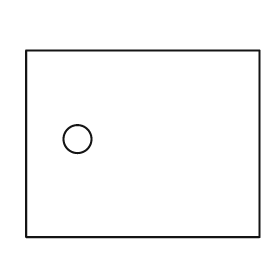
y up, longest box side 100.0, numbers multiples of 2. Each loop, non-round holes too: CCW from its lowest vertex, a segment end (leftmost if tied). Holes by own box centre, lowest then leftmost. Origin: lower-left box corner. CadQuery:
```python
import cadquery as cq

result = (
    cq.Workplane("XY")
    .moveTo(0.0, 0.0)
    .lineTo(100.0, 0.0)
    .lineTo(100.0, 80.0)
    .lineTo(0.0, 80.0)
    .close()
    .moveTo(22.0, 42.0)
    .circle(6.0)
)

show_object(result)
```